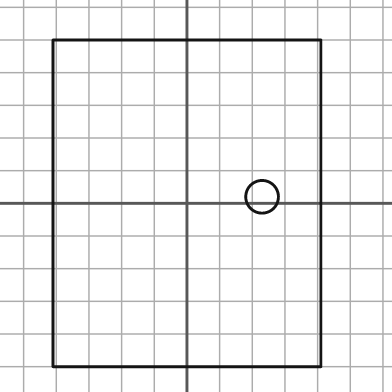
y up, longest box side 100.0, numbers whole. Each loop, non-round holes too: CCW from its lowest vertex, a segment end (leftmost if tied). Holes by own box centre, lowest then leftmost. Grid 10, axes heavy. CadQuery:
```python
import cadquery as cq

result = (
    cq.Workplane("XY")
    .moveTo(-41.0, -50.0)
    .lineTo(41.0, -50.0)
    .lineTo(41.0, 50.0)
    .lineTo(-41.0, 50.0)
    .close()
    .moveTo(23.0, 2.0)
    .circle(5.0)
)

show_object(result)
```